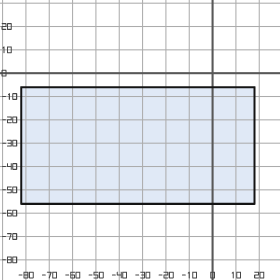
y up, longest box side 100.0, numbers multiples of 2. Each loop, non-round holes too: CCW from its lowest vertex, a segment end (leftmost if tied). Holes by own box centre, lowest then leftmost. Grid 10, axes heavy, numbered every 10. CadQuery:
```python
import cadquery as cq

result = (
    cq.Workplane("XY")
    .moveTo(-82.0, -56.0)
    .lineTo(18.0, -56.0)
    .lineTo(18.0, -6.0)
    .lineTo(-82.0, -6.0)
    .close()
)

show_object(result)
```